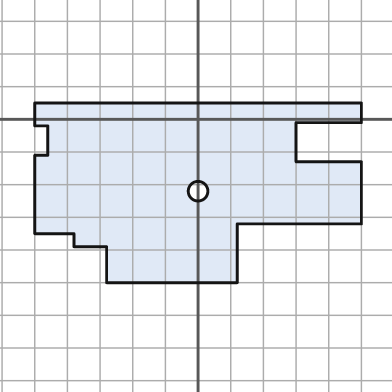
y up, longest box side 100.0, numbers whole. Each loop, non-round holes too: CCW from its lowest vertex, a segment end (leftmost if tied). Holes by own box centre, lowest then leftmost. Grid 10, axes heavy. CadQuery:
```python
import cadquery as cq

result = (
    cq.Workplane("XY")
    .moveTo(-28.0, -50.0)
    .lineTo(12.0, -50.0)
    .lineTo(12.0, -32.0)
    .lineTo(50.0, -32.0)
    .lineTo(50.0, -13.0)
    .lineTo(30.0, -13.0)
    .lineTo(30.0, -1.0)
    .lineTo(50.0, -1.0)
    .lineTo(50.0, 5.0)
    .lineTo(-50.0, 5.0)
    .lineTo(-50.0, -2.0)
    .lineTo(-46.0, -2.0)
    .lineTo(-46.0, -11.0)
    .lineTo(-50.0, -11.0)
    .lineTo(-50.0, -35.0)
    .lineTo(-38.0, -35.0)
    .lineTo(-38.0, -39.0)
    .lineTo(-28.0, -39.0)
    .close()
    .moveTo(0.0, -22.0)
    .circle(3.0)
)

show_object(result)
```